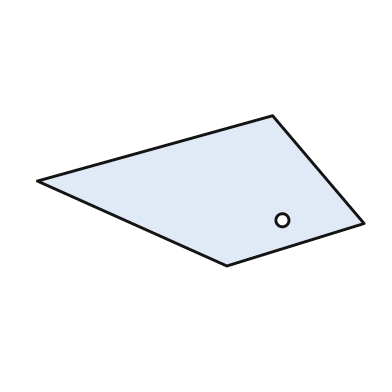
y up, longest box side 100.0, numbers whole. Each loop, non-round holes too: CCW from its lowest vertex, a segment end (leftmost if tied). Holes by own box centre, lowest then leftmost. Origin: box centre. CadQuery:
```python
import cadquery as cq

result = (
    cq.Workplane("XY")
    .moveTo(8.0, -23.0)
    .lineTo(50.0, -10.0)
    .lineTo(22.0, 23.0)
    .lineTo(-50.0, 3.0)
    .close()
    .moveTo(25.0, -9.0)
    .circle(2.0)
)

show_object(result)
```